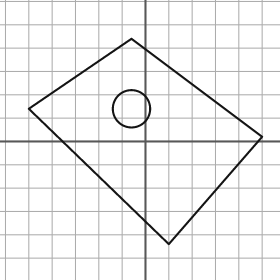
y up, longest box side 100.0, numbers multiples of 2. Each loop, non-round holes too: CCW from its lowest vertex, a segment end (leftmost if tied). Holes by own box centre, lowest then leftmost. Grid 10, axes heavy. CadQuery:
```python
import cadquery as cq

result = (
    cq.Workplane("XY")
    .moveTo(10.0, -44.0)
    .lineTo(50.0, 2.0)
    .lineTo(-6.0, 44.0)
    .lineTo(-50.0, 14.0)
    .close()
    .moveTo(-6.0, 14.0)
    .circle(8.0)
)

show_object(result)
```